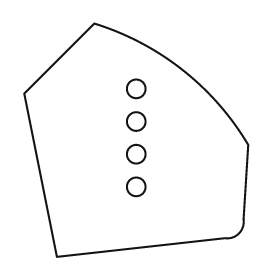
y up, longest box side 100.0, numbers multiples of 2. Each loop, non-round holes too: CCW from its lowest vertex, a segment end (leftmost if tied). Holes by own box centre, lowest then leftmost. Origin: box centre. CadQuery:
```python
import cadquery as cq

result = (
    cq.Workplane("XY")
    .moveTo(-34.0, -50.0)
    .lineTo(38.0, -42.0)
    .threePointArc((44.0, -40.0), (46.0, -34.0))
    .lineTo(48.0, -2.0)
    .threePointArc((20.0, 30.0), (-18.0, 50.0))
    .lineTo(-48.0, 20.0)
    .close()
    .moveTo(0.0, -20.0)
    .circle(4.0)
    .moveTo(0.0, -6.0)
    .circle(4.0)
    .moveTo(0.0, 8.0)
    .circle(4.0)
    .moveTo(0.0, 22.0)
    .circle(4.0)
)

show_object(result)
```